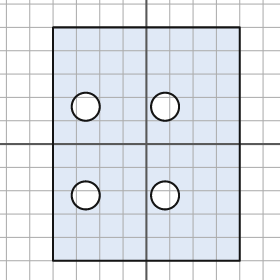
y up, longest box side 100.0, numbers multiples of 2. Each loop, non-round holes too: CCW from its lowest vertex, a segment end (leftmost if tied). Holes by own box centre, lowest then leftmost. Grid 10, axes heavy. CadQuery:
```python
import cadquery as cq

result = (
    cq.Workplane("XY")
    .moveTo(-40.0, -50.0)
    .lineTo(40.0, -50.0)
    .lineTo(40.0, 50.0)
    .lineTo(-40.0, 50.0)
    .close()
    .moveTo(-26.0, -22.0)
    .circle(6.0)
    .moveTo(8.0, -22.0)
    .circle(6.0)
    .moveTo(-26.0, 16.0)
    .circle(6.0)
    .moveTo(8.0, 16.0)
    .circle(6.0)
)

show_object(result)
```